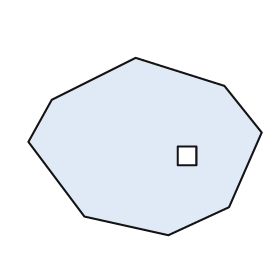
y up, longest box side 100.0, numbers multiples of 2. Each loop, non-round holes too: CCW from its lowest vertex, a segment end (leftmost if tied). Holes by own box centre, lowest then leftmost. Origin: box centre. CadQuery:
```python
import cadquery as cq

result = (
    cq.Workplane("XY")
    .moveTo(10.0, -38.0)
    .lineTo(36.0, -26.0)
    .lineTo(50.0, 6.0)
    .lineTo(34.0, 26.0)
    .lineTo(-4.0, 38.0)
    .lineTo(-40.0, 20.0)
    .lineTo(-50.0, 2.0)
    .lineTo(-26.0, -30.0)
    .close()
    .moveTo(14.0, -8.0)
    .lineTo(22.0, -8.0)
    .lineTo(22.0, 0.0)
    .lineTo(14.0, 0.0)
    .close()
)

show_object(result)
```